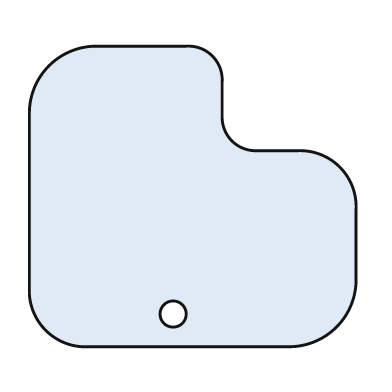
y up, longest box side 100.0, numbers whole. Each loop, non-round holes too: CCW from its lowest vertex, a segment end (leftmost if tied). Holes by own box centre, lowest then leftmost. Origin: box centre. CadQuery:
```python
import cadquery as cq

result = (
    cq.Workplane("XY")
    .moveTo(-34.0, -46.0)
    .lineTo(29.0, -46.0)
    .threePointArc((44.0, -40.0), (50.0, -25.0))
    .lineTo(50.0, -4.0)
    .threePointArc((45.0, 9.0), (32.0, 14.0))
    .lineTo(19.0, 14.0)
    .threePointArc((12.0, 17.0), (9.0, 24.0))
    .lineTo(9.0, 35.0)
    .threePointArc((6.0, 43.0), (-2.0, 46.0))
    .lineTo(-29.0, 46.0)
    .threePointArc((-44.0, 40.0), (-50.0, 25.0))
    .lineTo(-50.0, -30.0)
    .threePointArc((-45.0, -41.0), (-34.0, -46.0))
    .close()
    .moveTo(-6.0, -36.0)
    .circle(4.0)
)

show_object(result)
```